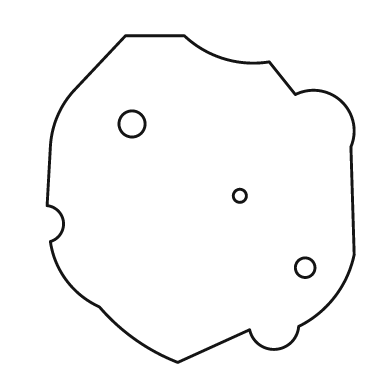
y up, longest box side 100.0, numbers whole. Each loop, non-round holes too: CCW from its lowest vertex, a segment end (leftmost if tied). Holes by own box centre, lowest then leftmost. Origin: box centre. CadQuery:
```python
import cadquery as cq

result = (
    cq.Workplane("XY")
    .moveTo(-7.0, -50.0)
    .lineTo(15.0, -40.0)
    .threePointArc((23.0, -46.0), (30.0, -39.0))
    .threePointArc((41.0, -30.0), (47.0, -17.0))
    .lineTo(46.0, 16.0)
    .threePointArc((43.0, 30.0), (29.0, 32.0))
    .lineTo(21.0, 42.0)
    .threePointArc((7.0, 43.0), (-5.0, 50.0))
    .lineTo(-23.0, 50.0)
    .lineTo(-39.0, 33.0)
    .threePointArc((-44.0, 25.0), (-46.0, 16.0))
    .lineTo(-47.0, -2.0)
    .threePointArc((-42.0, -7.0), (-46.0, -13.0))
    .threePointArc((-41.0, -25.0), (-31.0, -33.0))
    .threePointArc((-20.0, -43.0), (-7.0, -50.0))
    .close()
    .moveTo(32.0, -21.0)
    .circle(3.0)
    .moveTo(12.0, 1.0)
    .circle(2.0)
    .moveTo(-21.0, 23.0)
    .circle(4.0)
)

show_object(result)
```